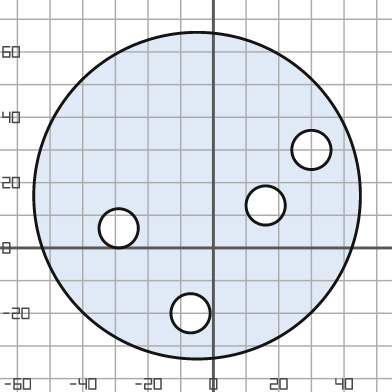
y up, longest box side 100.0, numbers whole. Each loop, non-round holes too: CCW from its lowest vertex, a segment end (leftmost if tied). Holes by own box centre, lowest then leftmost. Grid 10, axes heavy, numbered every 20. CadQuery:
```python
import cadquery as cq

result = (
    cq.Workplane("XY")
    .moveTo(-5.0, 16.0)
    .circle(50.0)
    .moveTo(-7.0, -20.0)
    .circle(6.0)
    .moveTo(-29.0, 6.0)
    .circle(6.0)
    .moveTo(16.0, 13.0)
    .circle(6.0)
    .moveTo(30.0, 30.0)
    .circle(6.0)
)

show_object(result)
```